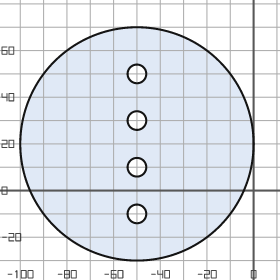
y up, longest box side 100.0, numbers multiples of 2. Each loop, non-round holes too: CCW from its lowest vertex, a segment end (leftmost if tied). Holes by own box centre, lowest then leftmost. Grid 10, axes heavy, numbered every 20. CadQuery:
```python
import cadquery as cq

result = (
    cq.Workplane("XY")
    .moveTo(-50.0, 20.0)
    .circle(50.0)
    .moveTo(-50.0, -10.0)
    .circle(4.0)
    .moveTo(-50.0, 10.0)
    .circle(4.0)
    .moveTo(-50.0, 30.0)
    .circle(4.0)
    .moveTo(-50.0, 50.0)
    .circle(4.0)
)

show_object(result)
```